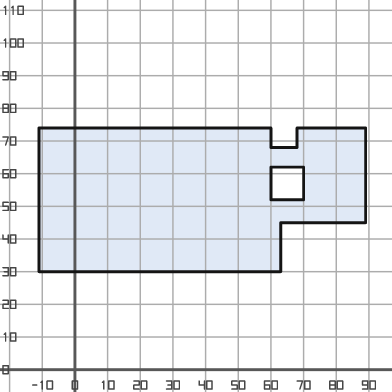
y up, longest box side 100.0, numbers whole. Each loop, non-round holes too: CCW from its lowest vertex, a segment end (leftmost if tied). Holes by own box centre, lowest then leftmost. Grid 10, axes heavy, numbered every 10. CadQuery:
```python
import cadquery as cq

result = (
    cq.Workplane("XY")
    .moveTo(-11.0, 30.0)
    .lineTo(63.0, 30.0)
    .lineTo(63.0, 45.0)
    .lineTo(89.0, 45.0)
    .lineTo(89.0, 74.0)
    .lineTo(68.0, 74.0)
    .lineTo(68.0, 68.0)
    .lineTo(60.0, 68.0)
    .lineTo(60.0, 74.0)
    .lineTo(-11.0, 74.0)
    .close()
    .moveTo(60.0, 52.0)
    .lineTo(70.0, 52.0)
    .lineTo(70.0, 62.0)
    .lineTo(60.0, 62.0)
    .close()
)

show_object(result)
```